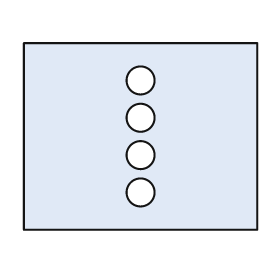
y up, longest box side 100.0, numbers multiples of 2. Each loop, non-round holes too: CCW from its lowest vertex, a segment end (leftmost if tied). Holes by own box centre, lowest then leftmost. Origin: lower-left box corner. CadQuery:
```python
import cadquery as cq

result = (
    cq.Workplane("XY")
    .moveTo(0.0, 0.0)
    .lineTo(100.0, 0.0)
    .lineTo(100.0, 80.0)
    .lineTo(0.0, 80.0)
    .close()
    .moveTo(50.0, 16.0)
    .circle(6.0)
    .moveTo(50.0, 32.0)
    .circle(6.0)
    .moveTo(50.0, 48.0)
    .circle(6.0)
    .moveTo(50.0, 64.0)
    .circle(6.0)
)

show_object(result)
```